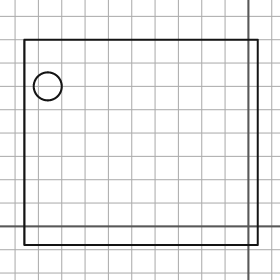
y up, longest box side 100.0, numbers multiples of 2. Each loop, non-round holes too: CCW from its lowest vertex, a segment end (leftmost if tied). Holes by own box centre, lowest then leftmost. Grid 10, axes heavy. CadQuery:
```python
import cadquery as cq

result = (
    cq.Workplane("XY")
    .moveTo(-96.0, -8.0)
    .lineTo(4.0, -8.0)
    .lineTo(4.0, 80.0)
    .lineTo(-96.0, 80.0)
    .close()
    .moveTo(-86.0, 60.0)
    .circle(6.0)
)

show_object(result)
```